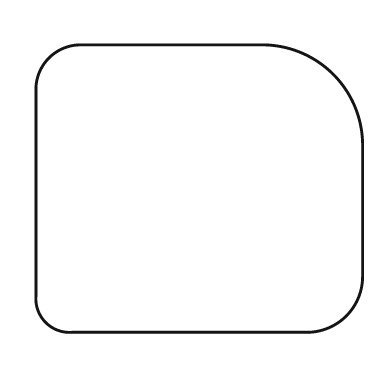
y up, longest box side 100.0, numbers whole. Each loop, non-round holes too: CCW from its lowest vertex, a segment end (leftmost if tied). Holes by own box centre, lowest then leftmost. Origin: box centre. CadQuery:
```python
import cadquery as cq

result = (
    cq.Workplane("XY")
    .moveTo(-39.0, -44.0)
    .lineTo(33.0, -44.0)
    .threePointArc((45.0, -39.0), (50.0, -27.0))
    .lineTo(50.0, 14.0)
    .threePointArc((41.0, 35.0), (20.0, 44.0))
    .lineTo(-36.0, 44.0)
    .threePointArc((-46.0, 40.0), (-50.0, 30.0))
    .lineTo(-50.0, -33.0)
    .threePointArc((-47.0, -41.0), (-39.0, -44.0))
    .close()
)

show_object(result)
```